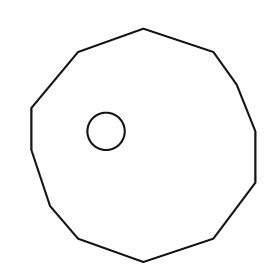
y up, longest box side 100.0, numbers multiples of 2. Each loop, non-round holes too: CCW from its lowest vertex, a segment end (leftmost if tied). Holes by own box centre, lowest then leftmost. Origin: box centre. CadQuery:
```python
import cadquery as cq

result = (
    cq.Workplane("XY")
    .moveTo(0.0, -50.0)
    .lineTo(30.0, -40.0)
    .lineTo(48.0, -16.0)
    .lineTo(48.0, 6.0)
    .lineTo(40.0, 26.0)
    .lineTo(30.0, 40.0)
    .lineTo(0.0, 50.0)
    .lineTo(-28.0, 40.0)
    .lineTo(-48.0, 16.0)
    .lineTo(-48.0, -2.0)
    .lineTo(-40.0, -26.0)
    .lineTo(-28.0, -40.0)
    .close()
    .moveTo(-16.0, 6.0)
    .circle(8.0)
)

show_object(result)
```